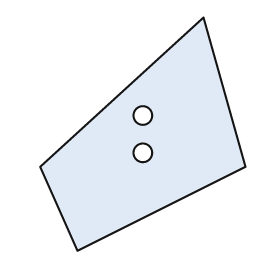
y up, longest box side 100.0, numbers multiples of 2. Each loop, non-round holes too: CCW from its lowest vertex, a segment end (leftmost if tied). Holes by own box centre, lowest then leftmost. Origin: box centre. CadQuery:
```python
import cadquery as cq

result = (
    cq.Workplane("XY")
    .moveTo(-28.0, -50.0)
    .lineTo(44.0, -14.0)
    .lineTo(26.0, 50.0)
    .lineTo(-44.0, -14.0)
    .close()
    .moveTo(0.0, -8.0)
    .circle(4.0)
    .moveTo(0.0, 8.0)
    .circle(4.0)
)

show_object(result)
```